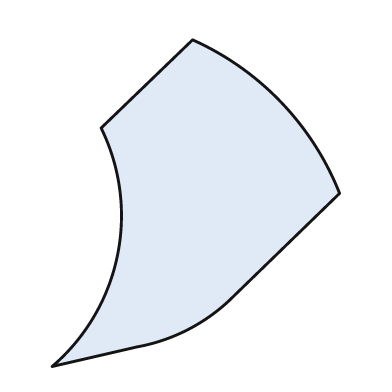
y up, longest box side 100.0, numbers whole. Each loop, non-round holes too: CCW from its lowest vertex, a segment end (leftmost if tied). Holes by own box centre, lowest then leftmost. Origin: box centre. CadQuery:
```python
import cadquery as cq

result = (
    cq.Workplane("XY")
    .moveTo(-44.0, -50.0)
    .lineTo(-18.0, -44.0)
    .threePointArc((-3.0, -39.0), (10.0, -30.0))
    .lineTo(44.0, 3.0)
    .threePointArc((26.0, 31.0), (-1.0, 50.0))
    .lineTo(-29.0, 23.0)
    .threePointArc((-24.0, -16.0), (-44.0, -50.0))
    .close()
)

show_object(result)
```